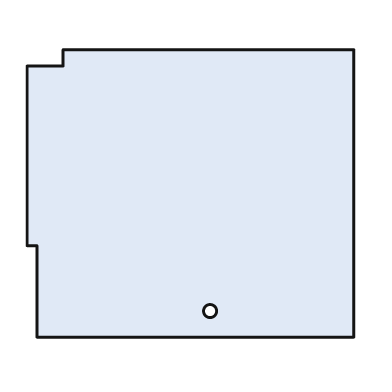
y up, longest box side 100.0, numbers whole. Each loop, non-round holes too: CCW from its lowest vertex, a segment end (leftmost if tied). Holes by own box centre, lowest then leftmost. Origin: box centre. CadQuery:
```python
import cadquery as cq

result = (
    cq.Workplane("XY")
    .moveTo(-47.0, -44.0)
    .lineTo(50.0, -44.0)
    .lineTo(50.0, 44.0)
    .lineTo(-39.0, 44.0)
    .lineTo(-39.0, 39.0)
    .lineTo(-50.0, 39.0)
    .lineTo(-50.0, -16.0)
    .lineTo(-47.0, -16.0)
    .close()
    .moveTo(6.0, -36.0)
    .circle(2.0)
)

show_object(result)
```